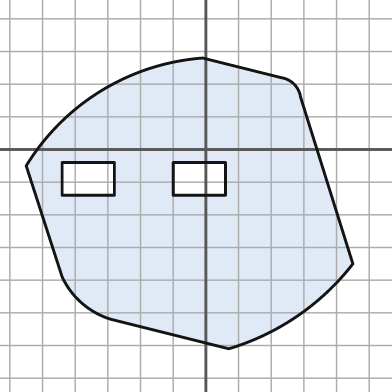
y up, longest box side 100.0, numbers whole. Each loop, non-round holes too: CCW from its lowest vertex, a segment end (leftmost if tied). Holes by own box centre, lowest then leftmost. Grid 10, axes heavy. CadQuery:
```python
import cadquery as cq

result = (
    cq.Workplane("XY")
    .moveTo(7.0, -61.0)
    .threePointArc((28.0, -51.0), (45.0, -35.0))
    .lineTo(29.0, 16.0)
    .threePointArc((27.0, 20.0), (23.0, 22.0))
    .lineTo(-1.0, 28.0)
    .threePointArc((-32.0, 18.0), (-55.0, -5.0))
    .lineTo(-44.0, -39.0)
    .threePointArc((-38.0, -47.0), (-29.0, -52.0))
    .close()
    .moveTo(-44.0, -14.0)
    .lineTo(-28.0, -14.0)
    .lineTo(-28.0, -4.0)
    .lineTo(-44.0, -4.0)
    .close()
    .moveTo(-10.0, -14.0)
    .lineTo(6.0, -14.0)
    .lineTo(6.0, -4.0)
    .lineTo(-10.0, -4.0)
    .close()
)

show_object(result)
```